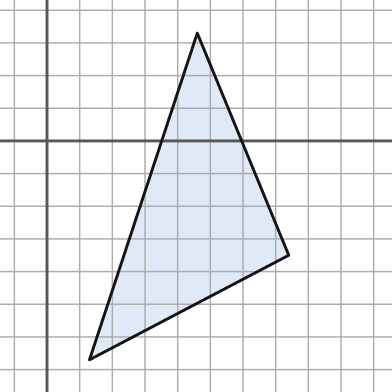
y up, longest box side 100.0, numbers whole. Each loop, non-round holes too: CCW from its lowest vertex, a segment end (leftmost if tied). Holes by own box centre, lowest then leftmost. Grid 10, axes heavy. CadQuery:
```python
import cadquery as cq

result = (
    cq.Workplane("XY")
    .moveTo(13.0, -67.0)
    .lineTo(74.0, -35.0)
    .lineTo(46.0, 33.0)
    .close()
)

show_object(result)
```